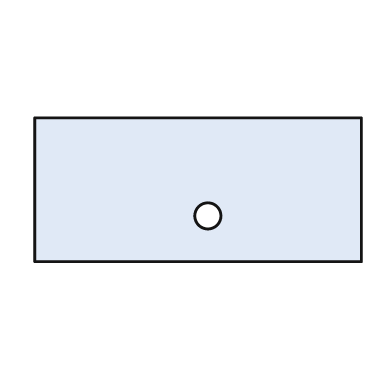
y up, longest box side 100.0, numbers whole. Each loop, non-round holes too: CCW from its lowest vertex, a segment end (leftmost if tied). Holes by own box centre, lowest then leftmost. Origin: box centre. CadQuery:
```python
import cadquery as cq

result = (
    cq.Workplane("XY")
    .moveTo(-50.0, -22.0)
    .lineTo(50.0, -22.0)
    .lineTo(50.0, 22.0)
    .lineTo(-50.0, 22.0)
    .close()
    .moveTo(3.0, -8.0)
    .circle(4.0)
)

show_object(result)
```